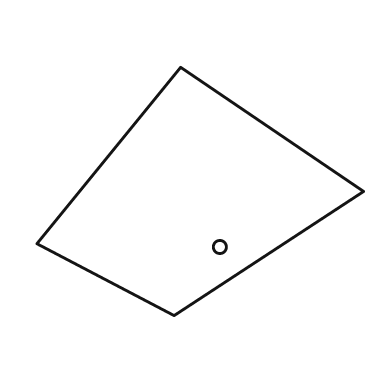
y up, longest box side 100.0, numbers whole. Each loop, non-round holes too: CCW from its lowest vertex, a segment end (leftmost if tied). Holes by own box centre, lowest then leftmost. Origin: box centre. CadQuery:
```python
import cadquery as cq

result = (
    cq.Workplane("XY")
    .moveTo(-8.0, -38.0)
    .lineTo(50.0, 0.0)
    .lineTo(-6.0, 38.0)
    .lineTo(-50.0, -16.0)
    .close()
    .moveTo(6.0, -17.0)
    .circle(2.0)
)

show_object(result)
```